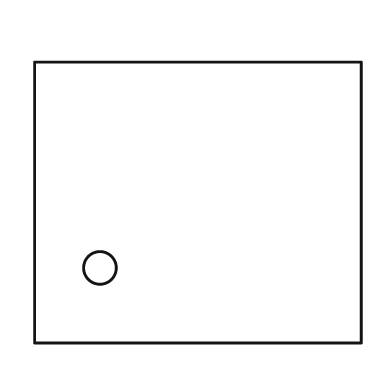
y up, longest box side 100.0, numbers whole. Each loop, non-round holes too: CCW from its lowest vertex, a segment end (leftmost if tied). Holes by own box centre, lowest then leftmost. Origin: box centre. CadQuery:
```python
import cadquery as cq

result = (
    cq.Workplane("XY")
    .moveTo(-50.0, -43.0)
    .lineTo(50.0, -43.0)
    .lineTo(50.0, 43.0)
    .lineTo(-50.0, 43.0)
    .close()
    .moveTo(-30.0, -20.0)
    .circle(5.0)
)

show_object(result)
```